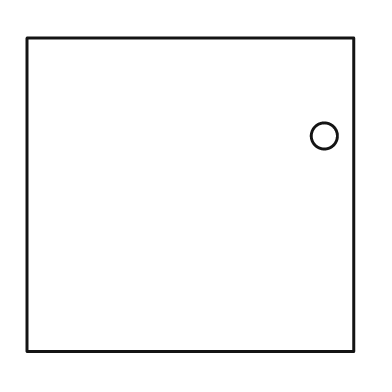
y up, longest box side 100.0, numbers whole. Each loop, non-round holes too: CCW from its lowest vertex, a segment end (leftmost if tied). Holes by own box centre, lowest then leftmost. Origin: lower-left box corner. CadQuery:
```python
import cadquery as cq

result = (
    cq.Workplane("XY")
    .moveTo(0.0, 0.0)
    .lineTo(100.0, 0.0)
    .lineTo(100.0, 96.0)
    .lineTo(0.0, 96.0)
    .close()
    .moveTo(91.0, 66.0)
    .circle(4.0)
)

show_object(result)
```